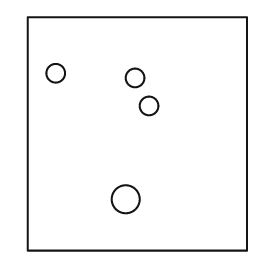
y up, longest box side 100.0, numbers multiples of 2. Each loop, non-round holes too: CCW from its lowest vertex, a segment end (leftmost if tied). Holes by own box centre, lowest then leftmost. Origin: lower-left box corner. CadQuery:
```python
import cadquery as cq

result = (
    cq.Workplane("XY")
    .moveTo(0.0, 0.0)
    .lineTo(94.0, 0.0)
    .lineTo(94.0, 100.0)
    .lineTo(0.0, 100.0)
    .close()
    .moveTo(42.0, 22.0)
    .circle(6.0)
    .moveTo(52.0, 62.0)
    .circle(4.0)
    .moveTo(46.0, 74.0)
    .circle(4.0)
    .moveTo(12.0, 76.0)
    .circle(4.0)
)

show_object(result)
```